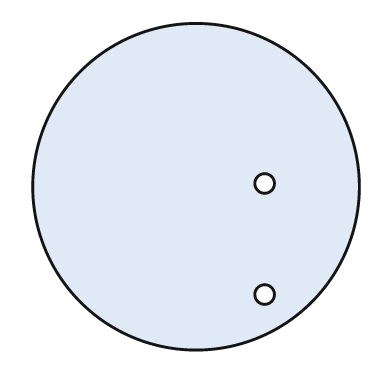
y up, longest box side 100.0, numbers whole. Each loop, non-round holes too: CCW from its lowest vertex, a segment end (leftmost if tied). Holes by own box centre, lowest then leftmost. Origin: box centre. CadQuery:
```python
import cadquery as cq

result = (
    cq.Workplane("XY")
    .moveTo(0.0, 0.0)
    .circle(50.0)
    .moveTo(21.0, -33.0)
    .circle(3.0)
    .moveTo(21.0, 1.0)
    .circle(3.0)
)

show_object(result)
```